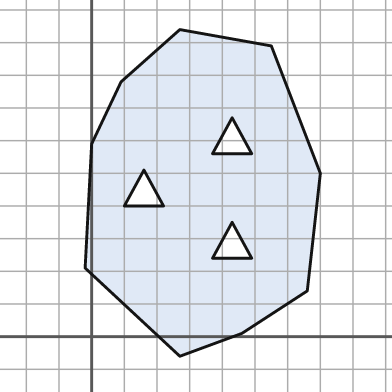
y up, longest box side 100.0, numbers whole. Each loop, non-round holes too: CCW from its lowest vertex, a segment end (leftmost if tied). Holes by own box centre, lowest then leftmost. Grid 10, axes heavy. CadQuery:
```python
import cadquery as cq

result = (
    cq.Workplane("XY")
    .moveTo(27.0, -6.0)
    .lineTo(46.0, 1.0)
    .lineTo(66.0, 14.0)
    .lineTo(70.0, 50.0)
    .lineTo(55.0, 89.0)
    .lineTo(27.0, 94.0)
    .lineTo(9.0, 78.0)
    .lineTo(0.0, 59.0)
    .lineTo(-2.0, 21.0)
    .close()
    .moveTo(37.0, 24.0)
    .lineTo(49.0, 24.0)
    .lineTo(43.0, 35.0)
    .close()
    .moveTo(10.0, 40.0)
    .lineTo(22.0, 40.0)
    .lineTo(16.0, 51.0)
    .close()
    .moveTo(37.0, 56.0)
    .lineTo(49.0, 56.0)
    .lineTo(43.0, 67.0)
    .close()
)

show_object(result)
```